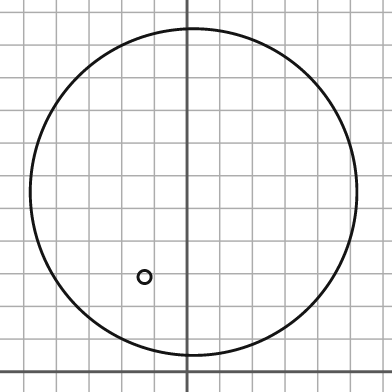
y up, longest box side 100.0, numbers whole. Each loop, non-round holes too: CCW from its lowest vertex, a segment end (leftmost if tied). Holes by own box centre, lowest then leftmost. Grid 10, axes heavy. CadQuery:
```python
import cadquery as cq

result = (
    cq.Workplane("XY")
    .moveTo(2.0, 55.0)
    .circle(50.0)
    .moveTo(-13.0, 29.0)
    .circle(2.0)
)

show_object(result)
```